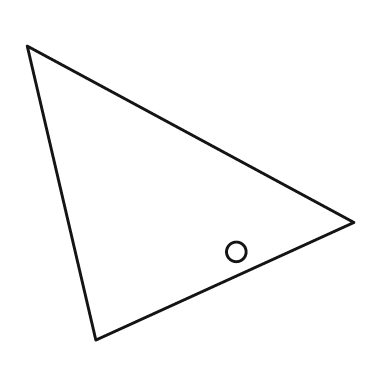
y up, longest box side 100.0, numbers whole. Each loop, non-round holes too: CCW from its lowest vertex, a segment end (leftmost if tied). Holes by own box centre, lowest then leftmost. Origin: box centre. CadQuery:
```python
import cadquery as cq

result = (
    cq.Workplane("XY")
    .moveTo(-29.0, -45.0)
    .lineTo(50.0, -9.0)
    .lineTo(-50.0, 45.0)
    .close()
    .moveTo(14.0, -18.0)
    .circle(3.0)
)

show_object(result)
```